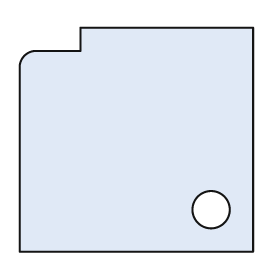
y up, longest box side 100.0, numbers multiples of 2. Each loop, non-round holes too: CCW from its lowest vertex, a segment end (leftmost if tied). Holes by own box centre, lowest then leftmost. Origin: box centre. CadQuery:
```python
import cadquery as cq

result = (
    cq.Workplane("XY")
    .moveTo(-50.0, -48.0)
    .lineTo(50.0, -48.0)
    .lineTo(50.0, 48.0)
    .lineTo(-24.0, 48.0)
    .lineTo(-24.0, 38.0)
    .lineTo(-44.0, 38.0)
    .threePointArc((-48.0, 36.0), (-50.0, 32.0))
    .close()
    .moveTo(32.0, -30.0)
    .circle(8.0)
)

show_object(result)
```